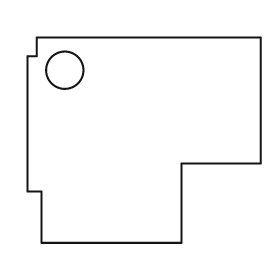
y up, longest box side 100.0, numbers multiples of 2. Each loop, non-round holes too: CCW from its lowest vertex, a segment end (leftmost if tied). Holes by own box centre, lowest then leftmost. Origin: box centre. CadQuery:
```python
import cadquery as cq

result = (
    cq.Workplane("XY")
    .moveTo(-44.0, -44.0)
    .lineTo(16.0, -44.0)
    .lineTo(16.0, -10.0)
    .lineTo(50.0, -10.0)
    .lineTo(50.0, 44.0)
    .lineTo(-46.0, 44.0)
    .lineTo(-46.0, 36.0)
    .lineTo(-50.0, 36.0)
    .lineTo(-50.0, -22.0)
    .lineTo(-44.0, -22.0)
    .close()
    .moveTo(-34.0, 30.0)
    .circle(8.0)
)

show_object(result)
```